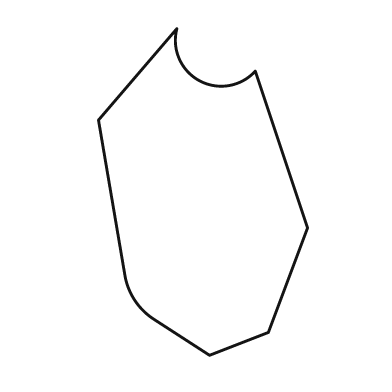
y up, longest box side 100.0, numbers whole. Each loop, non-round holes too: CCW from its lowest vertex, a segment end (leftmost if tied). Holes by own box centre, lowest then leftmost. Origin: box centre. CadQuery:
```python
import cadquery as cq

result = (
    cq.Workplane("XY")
    .moveTo(2.0, -50.0)
    .lineTo(20.0, -43.0)
    .lineTo(32.0, -11.0)
    .lineTo(16.0, 37.0)
    .threePointArc((-1.0, 34.0), (-8.0, 50.0))
    .lineTo(-32.0, 22.0)
    .lineTo(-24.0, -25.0)
    .threePointArc((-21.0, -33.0), (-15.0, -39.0))
    .close()
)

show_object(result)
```